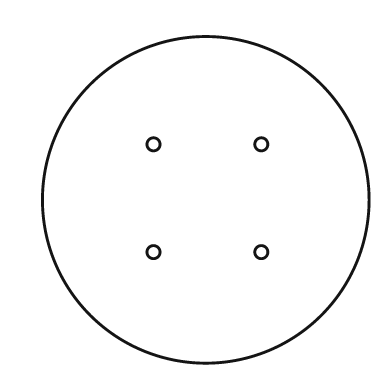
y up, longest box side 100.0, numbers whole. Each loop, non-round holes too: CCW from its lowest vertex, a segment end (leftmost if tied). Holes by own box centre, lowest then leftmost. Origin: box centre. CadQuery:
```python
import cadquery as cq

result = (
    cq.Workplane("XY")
    .moveTo(0.0, 0.0)
    .circle(50.0)
    .moveTo(-16.0, -16.0)
    .circle(2.0)
    .moveTo(17.0, -16.0)
    .circle(2.0)
    .moveTo(-16.0, 17.0)
    .circle(2.0)
    .moveTo(17.0, 17.0)
    .circle(2.0)
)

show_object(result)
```